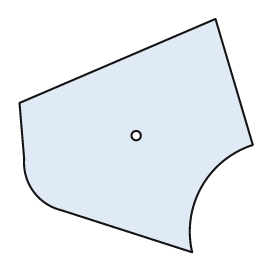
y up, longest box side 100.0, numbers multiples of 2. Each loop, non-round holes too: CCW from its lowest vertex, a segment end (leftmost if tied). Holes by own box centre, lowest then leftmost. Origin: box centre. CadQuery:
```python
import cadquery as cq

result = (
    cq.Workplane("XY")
    .moveTo(24.0, -50.0)
    .threePointArc((28.0, -22.0), (50.0, -4.0))
    .lineTo(34.0, 50.0)
    .lineTo(-50.0, 14.0)
    .lineTo(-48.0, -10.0)
    .threePointArc((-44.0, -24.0), (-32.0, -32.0))
    .close()
    .moveTo(0.0, 0.0)
    .circle(2.0)
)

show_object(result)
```